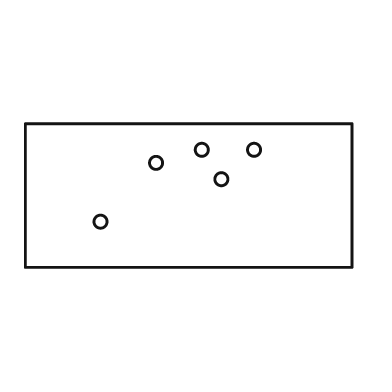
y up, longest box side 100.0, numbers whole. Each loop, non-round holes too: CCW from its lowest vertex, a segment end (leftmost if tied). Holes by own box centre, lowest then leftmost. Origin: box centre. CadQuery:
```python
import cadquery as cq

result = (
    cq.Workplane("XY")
    .moveTo(-50.0, -22.0)
    .lineTo(50.0, -22.0)
    .lineTo(50.0, 22.0)
    .lineTo(-50.0, 22.0)
    .close()
    .moveTo(-27.0, -8.0)
    .circle(2.0)
    .moveTo(10.0, 5.0)
    .circle(2.0)
    .moveTo(-10.0, 10.0)
    .circle(2.0)
    .moveTo(4.0, 14.0)
    .circle(2.0)
    .moveTo(20.0, 14.0)
    .circle(2.0)
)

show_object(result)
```